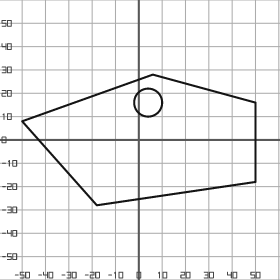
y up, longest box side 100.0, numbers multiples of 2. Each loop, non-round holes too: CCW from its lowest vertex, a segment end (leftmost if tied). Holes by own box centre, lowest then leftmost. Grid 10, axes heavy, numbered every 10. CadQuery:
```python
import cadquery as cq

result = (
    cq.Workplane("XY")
    .moveTo(-18.0, -28.0)
    .lineTo(50.0, -18.0)
    .lineTo(50.0, 16.0)
    .lineTo(6.0, 28.0)
    .lineTo(-50.0, 8.0)
    .close()
    .moveTo(4.0, 16.0)
    .circle(6.0)
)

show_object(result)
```